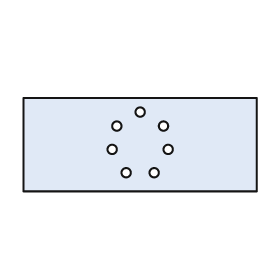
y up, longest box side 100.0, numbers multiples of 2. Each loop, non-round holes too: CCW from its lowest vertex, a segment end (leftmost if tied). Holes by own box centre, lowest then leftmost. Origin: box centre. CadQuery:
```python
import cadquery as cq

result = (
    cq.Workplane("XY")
    .moveTo(-50.0, -20.0)
    .lineTo(50.0, -20.0)
    .lineTo(50.0, 20.0)
    .lineTo(-50.0, 20.0)
    .close()
    .moveTo(-6.0, -12.0)
    .circle(2.0)
    .moveTo(6.0, -12.0)
    .circle(2.0)
    .moveTo(-12.0, -2.0)
    .circle(2.0)
    .moveTo(12.0, -2.0)
    .circle(2.0)
    .moveTo(-10.0, 8.0)
    .circle(2.0)
    .moveTo(10.0, 8.0)
    .circle(2.0)
    .moveTo(0.0, 14.0)
    .circle(2.0)
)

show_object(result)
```